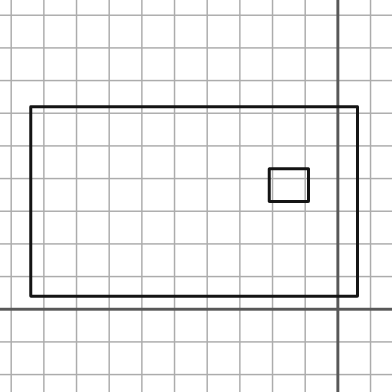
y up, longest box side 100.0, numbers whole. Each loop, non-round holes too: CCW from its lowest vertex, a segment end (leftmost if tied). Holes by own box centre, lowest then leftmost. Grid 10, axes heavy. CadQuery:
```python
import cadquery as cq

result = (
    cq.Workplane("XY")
    .moveTo(-94.0, 4.0)
    .lineTo(6.0, 4.0)
    .lineTo(6.0, 62.0)
    .lineTo(-94.0, 62.0)
    .close()
    .moveTo(-21.0, 33.0)
    .lineTo(-9.0, 33.0)
    .lineTo(-9.0, 43.0)
    .lineTo(-21.0, 43.0)
    .close()
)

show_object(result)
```